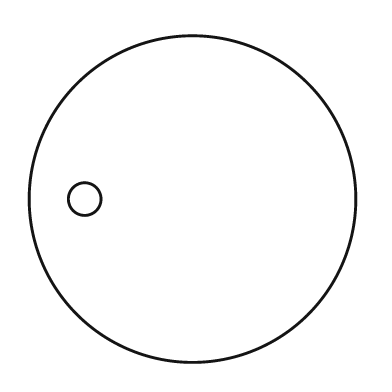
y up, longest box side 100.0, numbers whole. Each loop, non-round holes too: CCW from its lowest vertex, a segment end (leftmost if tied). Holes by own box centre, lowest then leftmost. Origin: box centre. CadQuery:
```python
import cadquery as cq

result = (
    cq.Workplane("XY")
    .moveTo(0.0, 0.0)
    .circle(50.0)
    .moveTo(-33.0, 0.0)
    .circle(5.0)
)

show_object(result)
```